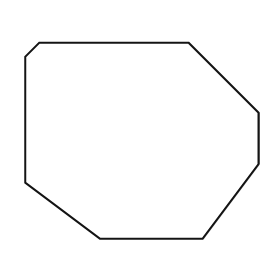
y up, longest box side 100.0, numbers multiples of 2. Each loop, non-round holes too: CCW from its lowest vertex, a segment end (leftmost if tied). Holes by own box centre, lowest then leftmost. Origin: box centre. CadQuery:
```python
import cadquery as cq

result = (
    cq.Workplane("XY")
    .moveTo(-18.0, -42.0)
    .lineTo(26.0, -42.0)
    .lineTo(50.0, -10.0)
    .lineTo(50.0, 12.0)
    .lineTo(20.0, 42.0)
    .lineTo(-44.0, 42.0)
    .lineTo(-50.0, 36.0)
    .lineTo(-50.0, -18.0)
    .close()
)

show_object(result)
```